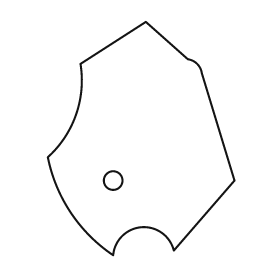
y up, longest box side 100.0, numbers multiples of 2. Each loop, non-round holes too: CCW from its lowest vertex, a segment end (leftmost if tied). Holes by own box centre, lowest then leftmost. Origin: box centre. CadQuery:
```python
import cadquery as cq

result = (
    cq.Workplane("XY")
    .moveTo(-12.0, -50.0)
    .threePointArc((0.0, -38.0), (14.0, -48.0))
    .lineTo(40.0, -18.0)
    .lineTo(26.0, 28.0)
    .threePointArc((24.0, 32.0), (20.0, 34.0))
    .lineTo(2.0, 50.0)
    .lineTo(-26.0, 32.0)
    .threePointArc((-28.0, 10.0), (-40.0, -8.0))
    .threePointArc((-30.0, -32.0), (-12.0, -50.0))
    .close()
    .moveTo(-12.0, -18.0)
    .circle(4.0)
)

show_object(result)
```